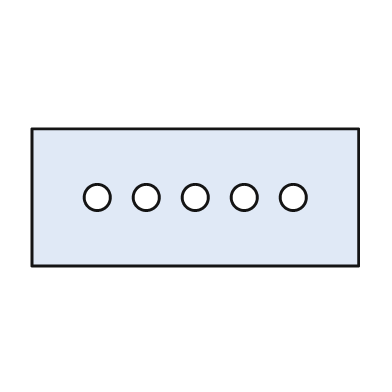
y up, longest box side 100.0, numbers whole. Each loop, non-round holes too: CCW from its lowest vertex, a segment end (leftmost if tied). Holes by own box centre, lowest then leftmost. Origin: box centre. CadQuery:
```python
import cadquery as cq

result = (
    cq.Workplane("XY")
    .moveTo(-50.0, -21.0)
    .lineTo(50.0, -21.0)
    .lineTo(50.0, 21.0)
    .lineTo(-50.0, 21.0)
    .close()
    .moveTo(-30.0, 0.0)
    .circle(4.0)
    .moveTo(-15.0, 0.0)
    .circle(4.0)
    .moveTo(0.0, 0.0)
    .circle(4.0)
    .moveTo(15.0, 0.0)
    .circle(4.0)
    .moveTo(30.0, 0.0)
    .circle(4.0)
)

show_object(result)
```